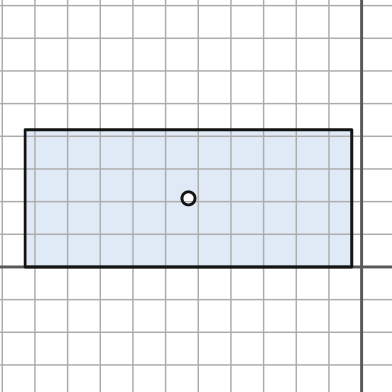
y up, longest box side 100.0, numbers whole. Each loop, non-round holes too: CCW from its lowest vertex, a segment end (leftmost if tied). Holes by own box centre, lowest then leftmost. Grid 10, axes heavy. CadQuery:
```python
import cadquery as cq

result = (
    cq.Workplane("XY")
    .moveTo(-103.0, 0.0)
    .lineTo(-3.0, 0.0)
    .lineTo(-3.0, 42.0)
    .lineTo(-103.0, 42.0)
    .close()
    .moveTo(-53.0, 21.0)
    .circle(2.0)
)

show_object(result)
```